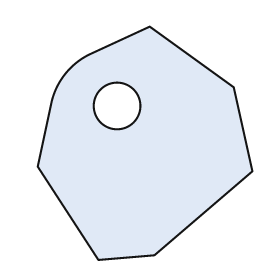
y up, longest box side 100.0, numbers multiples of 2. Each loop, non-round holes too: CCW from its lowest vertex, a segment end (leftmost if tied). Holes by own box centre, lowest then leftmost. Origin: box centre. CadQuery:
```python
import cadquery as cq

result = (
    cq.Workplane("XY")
    .moveTo(-20.0, -50.0)
    .lineTo(4.0, -48.0)
    .lineTo(46.0, -12.0)
    .lineTo(38.0, 24.0)
    .lineTo(2.0, 50.0)
    .lineTo(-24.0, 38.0)
    .threePointArc((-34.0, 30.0), (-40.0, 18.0))
    .lineTo(-46.0, -10.0)
    .close()
    .moveTo(-12.0, 16.0)
    .circle(10.0)
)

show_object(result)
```